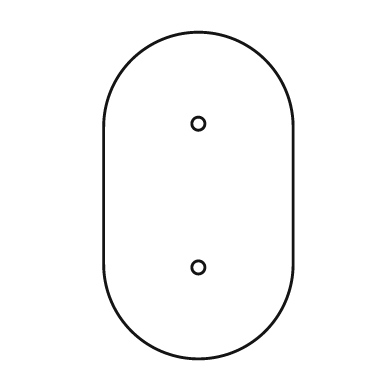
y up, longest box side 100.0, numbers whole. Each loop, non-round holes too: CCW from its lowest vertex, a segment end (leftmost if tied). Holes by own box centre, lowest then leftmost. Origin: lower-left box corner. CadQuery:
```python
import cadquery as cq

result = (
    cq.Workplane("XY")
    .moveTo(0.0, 29.0)
    .threePointArc((29.0, 0.0), (58.0, 29.0))
    .lineTo(58.0, 71.0)
    .threePointArc((29.0, 100.0), (0.0, 71.0))
    .close()
    .moveTo(29.0, 28.0)
    .circle(2.0)
    .moveTo(29.0, 72.0)
    .circle(2.0)
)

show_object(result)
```